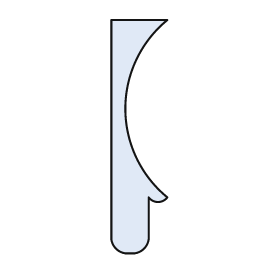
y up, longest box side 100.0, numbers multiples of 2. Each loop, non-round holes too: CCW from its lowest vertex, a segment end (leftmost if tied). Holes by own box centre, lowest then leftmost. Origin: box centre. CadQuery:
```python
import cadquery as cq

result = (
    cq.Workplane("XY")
    .moveTo(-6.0, -50.0)
    .lineTo(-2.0, -50.0)
    .threePointArc((2.0, -48.0), (4.0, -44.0))
    .lineTo(4.0, -26.0)
    .threePointArc((8.0, -28.0), (12.0, -26.0))
    .threePointArc((-6.0, 12.0), (12.0, 50.0))
    .lineTo(-12.0, 50.0)
    .lineTo(-12.0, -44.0)
    .threePointArc((-10.0, -48.0), (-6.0, -50.0))
    .close()
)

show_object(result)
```